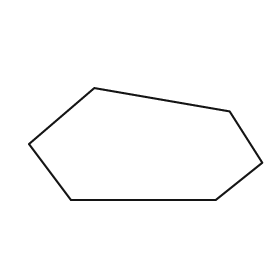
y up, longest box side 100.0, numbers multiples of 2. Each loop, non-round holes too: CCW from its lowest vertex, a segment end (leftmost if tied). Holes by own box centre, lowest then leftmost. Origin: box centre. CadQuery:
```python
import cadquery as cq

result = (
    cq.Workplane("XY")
    .moveTo(-32.0, -24.0)
    .lineTo(30.0, -24.0)
    .lineTo(50.0, -8.0)
    .lineTo(36.0, 14.0)
    .lineTo(-22.0, 24.0)
    .lineTo(-50.0, 0.0)
    .close()
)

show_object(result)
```